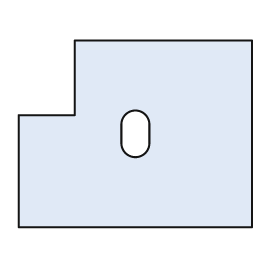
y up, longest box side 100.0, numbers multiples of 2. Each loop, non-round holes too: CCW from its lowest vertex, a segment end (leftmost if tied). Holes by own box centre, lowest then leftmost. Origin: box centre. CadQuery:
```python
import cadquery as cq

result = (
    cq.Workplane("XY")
    .moveTo(-50.0, -40.0)
    .lineTo(50.0, -40.0)
    .lineTo(50.0, 40.0)
    .lineTo(-26.0, 40.0)
    .lineTo(-26.0, 8.0)
    .lineTo(-50.0, 8.0)
    .close()
    .moveTo(-6.0, -4.0)
    .threePointArc((0.0, -10.0), (6.0, -4.0))
    .lineTo(6.0, 4.0)
    .threePointArc((0.0, 10.0), (-6.0, 4.0))
    .close()
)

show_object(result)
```